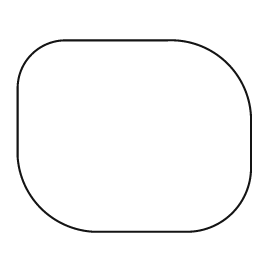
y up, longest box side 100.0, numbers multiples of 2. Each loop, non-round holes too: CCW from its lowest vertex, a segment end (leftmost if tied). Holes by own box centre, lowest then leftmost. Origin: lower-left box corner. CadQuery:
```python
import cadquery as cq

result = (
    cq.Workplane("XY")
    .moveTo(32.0, 0.0)
    .lineTo(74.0, 0.0)
    .threePointArc((92.0, 8.0), (100.0, 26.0))
    .lineTo(100.0, 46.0)
    .threePointArc((90.0, 72.0), (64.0, 82.0))
    .lineTo(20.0, 82.0)
    .threePointArc((6.0, 76.0), (0.0, 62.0))
    .lineTo(0.0, 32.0)
    .threePointArc((10.0, 10.0), (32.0, 0.0))
    .close()
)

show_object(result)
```